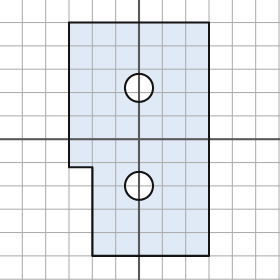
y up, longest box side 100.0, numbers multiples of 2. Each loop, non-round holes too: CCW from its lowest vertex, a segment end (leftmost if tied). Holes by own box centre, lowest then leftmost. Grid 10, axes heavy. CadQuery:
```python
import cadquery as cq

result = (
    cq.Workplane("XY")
    .moveTo(-20.0, -50.0)
    .lineTo(30.0, -50.0)
    .lineTo(30.0, 50.0)
    .lineTo(-30.0, 50.0)
    .lineTo(-30.0, -12.0)
    .lineTo(-20.0, -12.0)
    .close()
    .moveTo(0.0, -20.0)
    .circle(6.0)
    .moveTo(0.0, 22.0)
    .circle(6.0)
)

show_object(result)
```